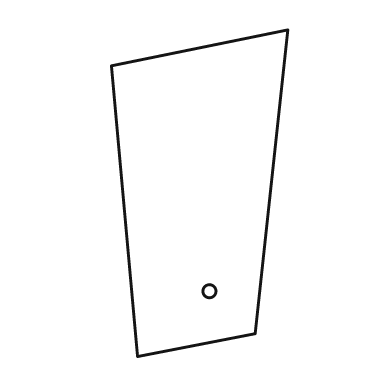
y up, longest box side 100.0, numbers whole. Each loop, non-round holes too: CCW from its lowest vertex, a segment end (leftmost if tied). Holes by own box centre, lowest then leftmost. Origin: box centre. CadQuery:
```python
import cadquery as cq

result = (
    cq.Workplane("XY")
    .moveTo(-19.0, -50.0)
    .lineTo(17.0, -43.0)
    .lineTo(27.0, 50.0)
    .lineTo(-27.0, 39.0)
    .close()
    .moveTo(3.0, -30.0)
    .circle(2.0)
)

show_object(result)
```